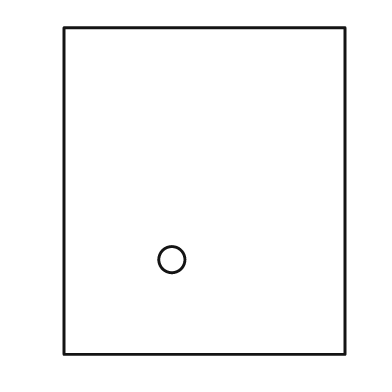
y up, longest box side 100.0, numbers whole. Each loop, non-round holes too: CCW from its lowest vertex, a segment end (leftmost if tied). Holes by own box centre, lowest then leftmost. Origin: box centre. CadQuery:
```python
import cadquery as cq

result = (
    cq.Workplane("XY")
    .moveTo(-43.0, -50.0)
    .lineTo(43.0, -50.0)
    .lineTo(43.0, 50.0)
    .lineTo(-43.0, 50.0)
    .close()
    .moveTo(-10.0, -21.0)
    .circle(4.0)
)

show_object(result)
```